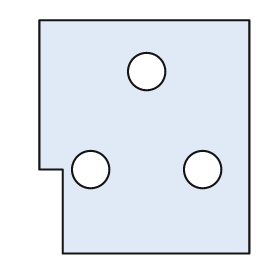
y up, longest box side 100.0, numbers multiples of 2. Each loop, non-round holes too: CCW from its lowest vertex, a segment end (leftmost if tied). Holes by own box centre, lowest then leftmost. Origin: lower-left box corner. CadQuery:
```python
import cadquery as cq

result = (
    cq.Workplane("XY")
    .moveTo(10.0, 0.0)
    .lineTo(90.0, 0.0)
    .lineTo(90.0, 100.0)
    .lineTo(0.0, 100.0)
    .lineTo(0.0, 36.0)
    .lineTo(10.0, 36.0)
    .close()
    .moveTo(22.0, 36.0)
    .circle(8.0)
    .moveTo(70.0, 36.0)
    .circle(8.0)
    .moveTo(46.0, 78.0)
    .circle(8.0)
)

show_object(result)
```